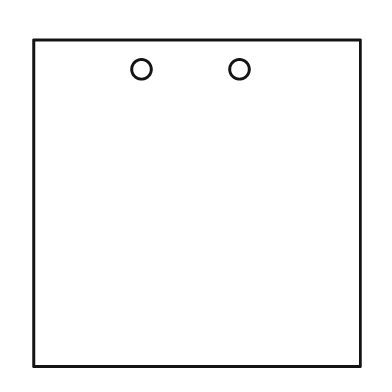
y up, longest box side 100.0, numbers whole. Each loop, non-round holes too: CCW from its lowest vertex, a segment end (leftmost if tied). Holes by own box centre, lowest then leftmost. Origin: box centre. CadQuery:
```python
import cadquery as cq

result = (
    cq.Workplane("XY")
    .moveTo(-50.0, -50.0)
    .lineTo(50.0, -50.0)
    .lineTo(50.0, 50.0)
    .lineTo(-50.0, 50.0)
    .close()
    .moveTo(-17.0, 41.0)
    .circle(3.0)
    .moveTo(13.0, 41.0)
    .circle(3.0)
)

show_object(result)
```